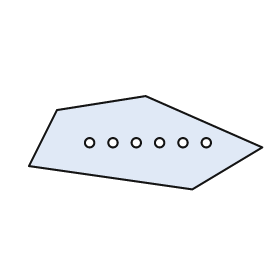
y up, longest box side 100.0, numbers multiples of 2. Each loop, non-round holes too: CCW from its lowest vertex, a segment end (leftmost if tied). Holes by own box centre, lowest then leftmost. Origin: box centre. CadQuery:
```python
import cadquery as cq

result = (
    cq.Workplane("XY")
    .moveTo(20.0, -20.0)
    .lineTo(50.0, -2.0)
    .lineTo(0.0, 20.0)
    .lineTo(-38.0, 14.0)
    .lineTo(-50.0, -10.0)
    .close()
    .moveTo(-24.0, 0.0)
    .circle(2.0)
    .moveTo(-14.0, 0.0)
    .circle(2.0)
    .moveTo(-4.0, 0.0)
    .circle(2.0)
    .moveTo(6.0, 0.0)
    .circle(2.0)
    .moveTo(16.0, 0.0)
    .circle(2.0)
    .moveTo(26.0, 0.0)
    .circle(2.0)
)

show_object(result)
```